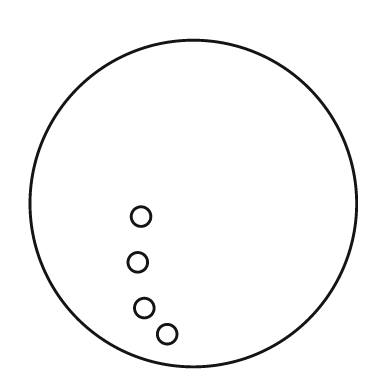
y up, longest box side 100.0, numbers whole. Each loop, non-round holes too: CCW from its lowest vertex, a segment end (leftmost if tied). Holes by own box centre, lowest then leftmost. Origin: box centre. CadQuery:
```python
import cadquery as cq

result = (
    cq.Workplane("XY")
    .moveTo(0.0, 0.0)
    .circle(50.0)
    .moveTo(-8.0, -40.0)
    .circle(3.0)
    .moveTo(-15.0, -32.0)
    .circle(3.0)
    .moveTo(-17.0, -18.0)
    .circle(3.0)
    .moveTo(-16.0, -4.0)
    .circle(3.0)
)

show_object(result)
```